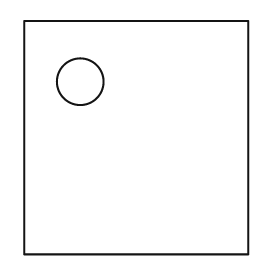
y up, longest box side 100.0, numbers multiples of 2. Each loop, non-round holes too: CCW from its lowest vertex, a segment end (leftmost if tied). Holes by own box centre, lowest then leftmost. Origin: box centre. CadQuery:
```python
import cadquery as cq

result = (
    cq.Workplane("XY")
    .moveTo(-48.0, -50.0)
    .lineTo(48.0, -50.0)
    .lineTo(48.0, 50.0)
    .lineTo(-48.0, 50.0)
    .close()
    .moveTo(-24.0, 24.0)
    .circle(10.0)
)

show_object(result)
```